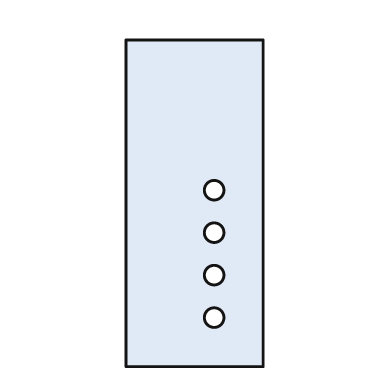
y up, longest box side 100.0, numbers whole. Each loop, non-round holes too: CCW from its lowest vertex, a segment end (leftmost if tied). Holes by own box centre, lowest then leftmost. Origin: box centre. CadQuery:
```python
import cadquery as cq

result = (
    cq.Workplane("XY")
    .moveTo(-21.0, -50.0)
    .lineTo(21.0, -50.0)
    .lineTo(21.0, 50.0)
    .lineTo(-21.0, 50.0)
    .close()
    .moveTo(6.0, -35.0)
    .circle(3.0)
    .moveTo(6.0, -22.0)
    .circle(3.0)
    .moveTo(6.0, -9.0)
    .circle(3.0)
    .moveTo(6.0, 4.0)
    .circle(3.0)
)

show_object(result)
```